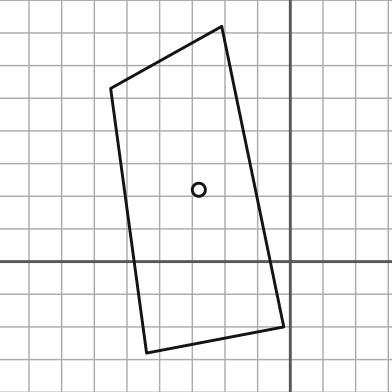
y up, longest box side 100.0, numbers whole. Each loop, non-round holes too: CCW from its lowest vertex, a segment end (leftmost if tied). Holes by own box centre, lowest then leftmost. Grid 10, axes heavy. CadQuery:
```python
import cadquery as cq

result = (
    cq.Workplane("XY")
    .moveTo(-44.0, -28.0)
    .lineTo(-2.0, -20.0)
    .lineTo(-21.0, 72.0)
    .lineTo(-55.0, 53.0)
    .close()
    .moveTo(-28.0, 22.0)
    .circle(2.0)
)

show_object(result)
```